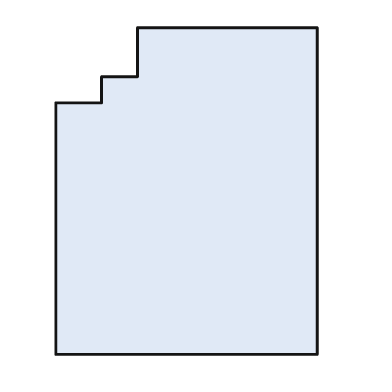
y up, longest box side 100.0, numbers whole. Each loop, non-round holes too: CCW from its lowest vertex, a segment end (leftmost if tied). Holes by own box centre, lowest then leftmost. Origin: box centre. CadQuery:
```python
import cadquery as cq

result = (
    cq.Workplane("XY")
    .moveTo(-40.0, -50.0)
    .lineTo(40.0, -50.0)
    .lineTo(40.0, 50.0)
    .lineTo(-15.0, 50.0)
    .lineTo(-15.0, 35.0)
    .lineTo(-26.0, 35.0)
    .lineTo(-26.0, 27.0)
    .lineTo(-40.0, 27.0)
    .close()
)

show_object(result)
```